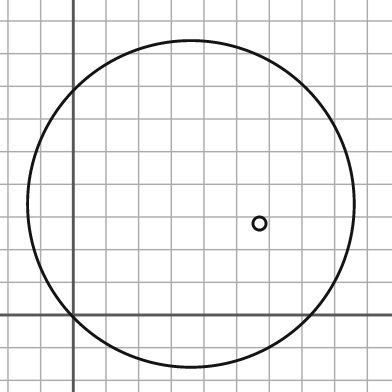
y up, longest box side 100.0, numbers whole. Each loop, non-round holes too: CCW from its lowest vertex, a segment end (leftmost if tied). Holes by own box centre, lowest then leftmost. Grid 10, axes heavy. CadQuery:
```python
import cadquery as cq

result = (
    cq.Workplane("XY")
    .moveTo(36.0, 34.0)
    .circle(50.0)
    .moveTo(57.0, 28.0)
    .circle(2.0)
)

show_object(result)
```